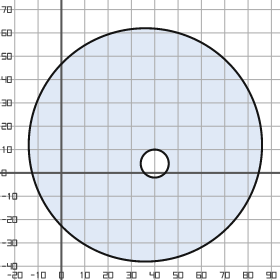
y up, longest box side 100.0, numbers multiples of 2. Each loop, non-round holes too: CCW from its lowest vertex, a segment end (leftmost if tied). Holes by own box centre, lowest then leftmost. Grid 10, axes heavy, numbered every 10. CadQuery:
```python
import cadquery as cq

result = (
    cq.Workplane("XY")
    .moveTo(36.0, 12.0)
    .circle(50.0)
    .moveTo(40.0, 4.0)
    .circle(6.0)
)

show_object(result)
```